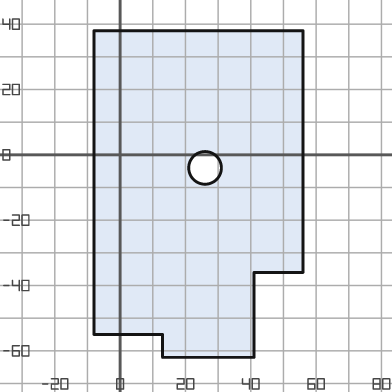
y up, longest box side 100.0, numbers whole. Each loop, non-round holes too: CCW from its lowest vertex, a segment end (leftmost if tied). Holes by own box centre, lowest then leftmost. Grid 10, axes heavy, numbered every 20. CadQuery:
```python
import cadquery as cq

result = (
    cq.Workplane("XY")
    .moveTo(13.0, -62.0)
    .lineTo(41.0, -62.0)
    .lineTo(41.0, -36.0)
    .lineTo(56.0, -36.0)
    .lineTo(56.0, 38.0)
    .lineTo(-8.0, 38.0)
    .lineTo(-8.0, -55.0)
    .lineTo(13.0, -55.0)
    .close()
    .moveTo(26.0, -4.0)
    .circle(5.0)
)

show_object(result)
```